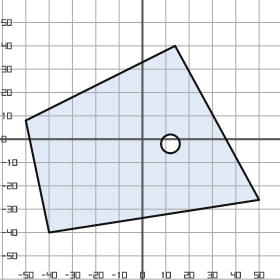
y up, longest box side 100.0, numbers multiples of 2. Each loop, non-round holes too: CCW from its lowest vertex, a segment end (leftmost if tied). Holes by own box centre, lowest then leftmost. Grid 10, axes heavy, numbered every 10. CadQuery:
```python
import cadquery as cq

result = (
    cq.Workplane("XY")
    .moveTo(-40.0, -40.0)
    .lineTo(50.0, -26.0)
    .lineTo(14.0, 40.0)
    .lineTo(-50.0, 8.0)
    .close()
    .moveTo(12.0, -2.0)
    .circle(4.0)
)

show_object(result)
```